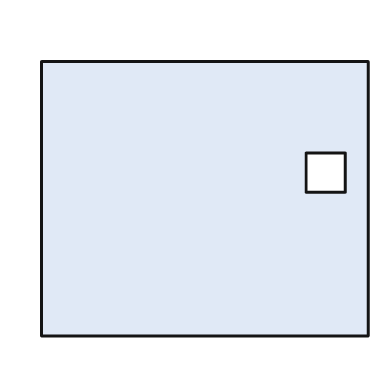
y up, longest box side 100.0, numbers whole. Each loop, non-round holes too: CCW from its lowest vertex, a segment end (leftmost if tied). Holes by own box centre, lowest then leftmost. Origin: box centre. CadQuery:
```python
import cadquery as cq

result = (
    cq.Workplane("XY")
    .moveTo(-50.0, -42.0)
    .lineTo(50.0, -42.0)
    .lineTo(50.0, 42.0)
    .lineTo(-50.0, 42.0)
    .close()
    .moveTo(31.0, 2.0)
    .lineTo(43.0, 2.0)
    .lineTo(43.0, 14.0)
    .lineTo(31.0, 14.0)
    .close()
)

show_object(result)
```